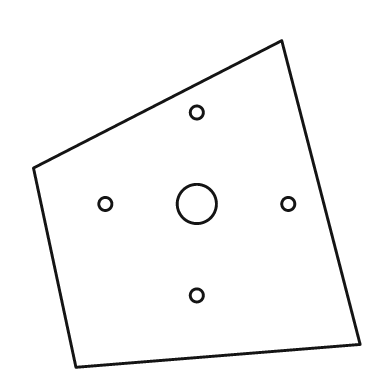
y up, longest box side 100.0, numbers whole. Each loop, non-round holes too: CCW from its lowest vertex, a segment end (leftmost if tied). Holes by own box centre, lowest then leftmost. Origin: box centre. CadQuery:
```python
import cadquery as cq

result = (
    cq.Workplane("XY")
    .moveTo(-37.0, -50.0)
    .lineTo(50.0, -43.0)
    .lineTo(26.0, 50.0)
    .lineTo(-50.0, 11.0)
    .close()
    .moveTo(0.0, -28.0)
    .circle(2.0)
    .moveTo(-28.0, 0.0)
    .circle(2.0)
    .moveTo(0.0, 0.0)
    .circle(6.0)
    .moveTo(28.0, 0.0)
    .circle(2.0)
    .moveTo(0.0, 28.0)
    .circle(2.0)
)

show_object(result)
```